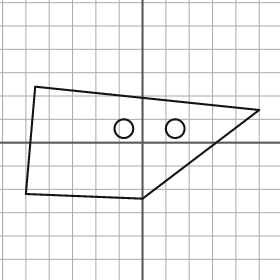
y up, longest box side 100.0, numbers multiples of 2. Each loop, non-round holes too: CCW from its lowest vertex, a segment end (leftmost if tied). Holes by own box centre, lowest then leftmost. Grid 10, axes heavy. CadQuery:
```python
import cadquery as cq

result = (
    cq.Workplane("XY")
    .moveTo(0.0, -24.0)
    .lineTo(50.0, 14.0)
    .lineTo(-46.0, 24.0)
    .lineTo(-50.0, -22.0)
    .close()
    .moveTo(-8.0, 6.0)
    .circle(4.0)
    .moveTo(14.0, 6.0)
    .circle(4.0)
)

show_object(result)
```